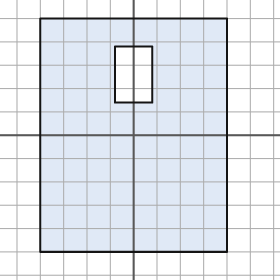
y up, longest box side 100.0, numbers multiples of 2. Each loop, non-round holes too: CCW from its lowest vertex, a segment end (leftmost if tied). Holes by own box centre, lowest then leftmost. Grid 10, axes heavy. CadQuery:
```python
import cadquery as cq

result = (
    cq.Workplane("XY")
    .moveTo(-40.0, -50.0)
    .lineTo(40.0, -50.0)
    .lineTo(40.0, 50.0)
    .lineTo(-40.0, 50.0)
    .close()
    .moveTo(-8.0, 14.0)
    .lineTo(8.0, 14.0)
    .lineTo(8.0, 38.0)
    .lineTo(-8.0, 38.0)
    .close()
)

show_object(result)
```